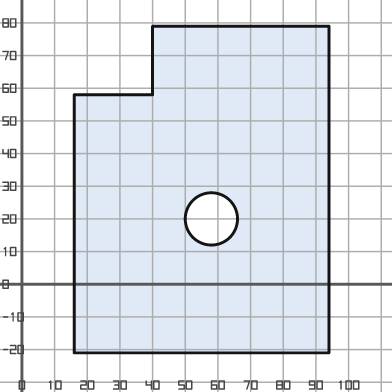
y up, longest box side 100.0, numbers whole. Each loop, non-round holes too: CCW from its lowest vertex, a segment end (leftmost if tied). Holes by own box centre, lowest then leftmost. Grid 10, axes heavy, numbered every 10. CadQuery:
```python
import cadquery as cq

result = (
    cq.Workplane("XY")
    .moveTo(16.0, -21.0)
    .lineTo(94.0, -21.0)
    .lineTo(94.0, 79.0)
    .lineTo(40.0, 79.0)
    .lineTo(40.0, 58.0)
    .lineTo(16.0, 58.0)
    .close()
    .moveTo(58.0, 20.0)
    .circle(8.0)
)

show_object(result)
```